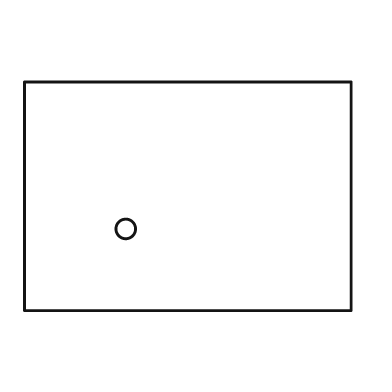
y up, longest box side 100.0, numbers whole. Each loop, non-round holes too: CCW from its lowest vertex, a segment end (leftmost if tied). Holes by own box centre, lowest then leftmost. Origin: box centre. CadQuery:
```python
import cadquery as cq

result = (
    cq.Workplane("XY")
    .moveTo(-50.0, -35.0)
    .lineTo(50.0, -35.0)
    .lineTo(50.0, 35.0)
    .lineTo(-50.0, 35.0)
    .close()
    .moveTo(-19.0, -10.0)
    .circle(3.0)
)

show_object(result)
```